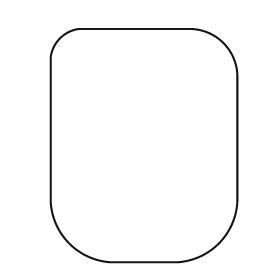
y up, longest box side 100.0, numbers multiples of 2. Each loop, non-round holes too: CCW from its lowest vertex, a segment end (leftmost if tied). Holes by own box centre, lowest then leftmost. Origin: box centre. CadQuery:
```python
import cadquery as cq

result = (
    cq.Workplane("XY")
    .moveTo(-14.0, -50.0)
    .lineTo(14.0, -50.0)
    .threePointArc((32.0, -42.0), (40.0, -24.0))
    .lineTo(40.0, 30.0)
    .threePointArc((34.0, 44.0), (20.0, 50.0))
    .lineTo(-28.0, 50.0)
    .threePointArc((-36.0, 46.0), (-40.0, 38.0))
    .lineTo(-40.0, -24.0)
    .threePointArc((-32.0, -42.0), (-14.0, -50.0))
    .close()
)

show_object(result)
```